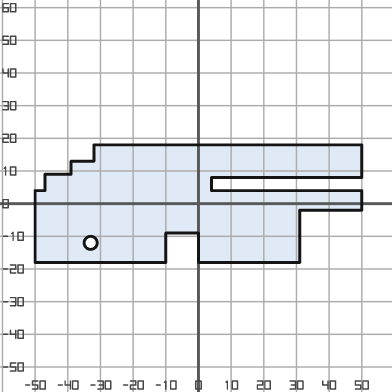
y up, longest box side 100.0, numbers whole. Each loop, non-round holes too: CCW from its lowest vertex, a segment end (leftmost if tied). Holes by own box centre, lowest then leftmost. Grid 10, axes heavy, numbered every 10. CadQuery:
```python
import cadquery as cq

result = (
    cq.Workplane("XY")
    .moveTo(-50.0, -18.0)
    .lineTo(-10.0, -18.0)
    .lineTo(-10.0, -9.0)
    .lineTo(0.0, -9.0)
    .lineTo(0.0, -18.0)
    .lineTo(31.0, -18.0)
    .lineTo(31.0, -2.0)
    .lineTo(50.0, -2.0)
    .lineTo(50.0, 4.0)
    .lineTo(4.0, 4.0)
    .lineTo(4.0, 8.0)
    .lineTo(50.0, 8.0)
    .lineTo(50.0, 18.0)
    .lineTo(-32.0, 18.0)
    .lineTo(-32.0, 13.0)
    .lineTo(-39.0, 13.0)
    .lineTo(-39.0, 9.0)
    .lineTo(-47.0, 9.0)
    .lineTo(-47.0, 4.0)
    .lineTo(-50.0, 4.0)
    .close()
    .moveTo(-33.0, -12.0)
    .circle(2.0)
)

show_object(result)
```